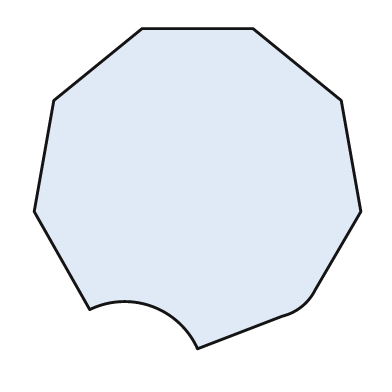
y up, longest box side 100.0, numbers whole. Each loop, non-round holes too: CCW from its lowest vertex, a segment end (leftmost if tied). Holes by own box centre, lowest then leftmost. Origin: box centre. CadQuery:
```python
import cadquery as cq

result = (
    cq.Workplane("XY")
    .moveTo(0.0, -49.0)
    .lineTo(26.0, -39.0)
    .threePointArc((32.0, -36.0), (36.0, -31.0))
    .lineTo(50.0, -7.0)
    .lineTo(44.0, 27.0)
    .lineTo(17.0, 49.0)
    .lineTo(-17.0, 49.0)
    .lineTo(-44.0, 27.0)
    .lineTo(-50.0, -7.0)
    .lineTo(-33.0, -37.0)
    .threePointArc((-14.0, -36.0), (0.0, -49.0))
    .close()
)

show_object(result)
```